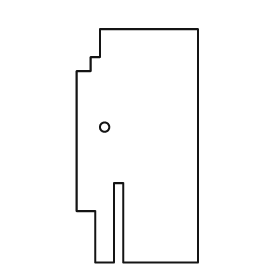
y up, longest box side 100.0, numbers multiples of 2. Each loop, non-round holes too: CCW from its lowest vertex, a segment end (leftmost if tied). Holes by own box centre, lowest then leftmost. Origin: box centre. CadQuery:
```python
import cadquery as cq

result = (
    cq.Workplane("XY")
    .moveTo(-18.0, -50.0)
    .lineTo(-10.0, -50.0)
    .lineTo(-10.0, -16.0)
    .lineTo(-6.0, -16.0)
    .lineTo(-6.0, -50.0)
    .lineTo(26.0, -50.0)
    .lineTo(26.0, 50.0)
    .lineTo(-16.0, 50.0)
    .lineTo(-16.0, 38.0)
    .lineTo(-20.0, 38.0)
    .lineTo(-20.0, 32.0)
    .lineTo(-26.0, 32.0)
    .lineTo(-26.0, -28.0)
    .lineTo(-18.0, -28.0)
    .close()
    .moveTo(-14.0, 8.0)
    .circle(2.0)
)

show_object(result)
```